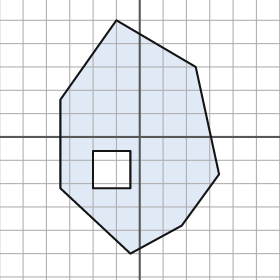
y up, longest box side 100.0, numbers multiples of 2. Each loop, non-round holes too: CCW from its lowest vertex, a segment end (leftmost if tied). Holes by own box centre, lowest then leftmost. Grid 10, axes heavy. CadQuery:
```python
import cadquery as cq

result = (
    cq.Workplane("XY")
    .moveTo(-4.0, -50.0)
    .lineTo(18.0, -38.0)
    .lineTo(34.0, -16.0)
    .lineTo(24.0, 30.0)
    .lineTo(-10.0, 50.0)
    .lineTo(-34.0, 16.0)
    .lineTo(-34.0, -22.0)
    .close()
    .moveTo(-20.0, -22.0)
    .lineTo(-4.0, -22.0)
    .lineTo(-4.0, -6.0)
    .lineTo(-20.0, -6.0)
    .close()
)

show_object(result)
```